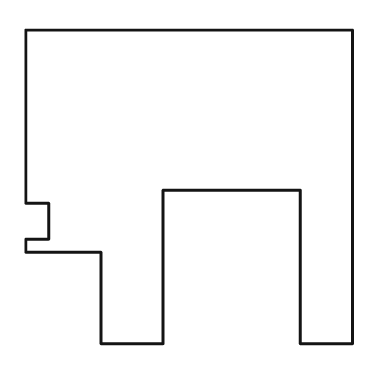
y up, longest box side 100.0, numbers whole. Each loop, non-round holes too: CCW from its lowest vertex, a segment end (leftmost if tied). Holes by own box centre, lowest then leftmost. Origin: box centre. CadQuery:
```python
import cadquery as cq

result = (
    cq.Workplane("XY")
    .moveTo(-27.0, -48.0)
    .lineTo(-8.0, -48.0)
    .lineTo(-8.0, -1.0)
    .lineTo(34.0, -1.0)
    .lineTo(34.0, -48.0)
    .lineTo(50.0, -48.0)
    .lineTo(50.0, 48.0)
    .lineTo(-50.0, 48.0)
    .lineTo(-50.0, -5.0)
    .lineTo(-43.0, -5.0)
    .lineTo(-43.0, -16.0)
    .lineTo(-50.0, -16.0)
    .lineTo(-50.0, -20.0)
    .lineTo(-27.0, -20.0)
    .close()
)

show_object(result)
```